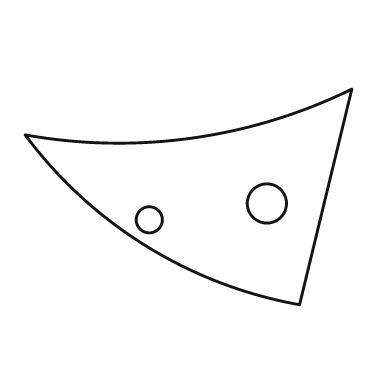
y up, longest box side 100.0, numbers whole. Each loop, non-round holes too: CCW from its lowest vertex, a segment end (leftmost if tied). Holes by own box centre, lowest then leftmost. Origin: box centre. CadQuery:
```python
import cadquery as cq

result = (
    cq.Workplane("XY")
    .moveTo(34.0, -33.0)
    .lineTo(50.0, 33.0)
    .threePointArc((1.0, 18.0), (-50.0, 19.0))
    .threePointArc((-13.0, -15.0), (34.0, -33.0))
    .close()
    .moveTo(-12.0, -7.0)
    .circle(4.0)
    .moveTo(24.0, -2.0)
    .circle(6.0)
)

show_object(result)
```